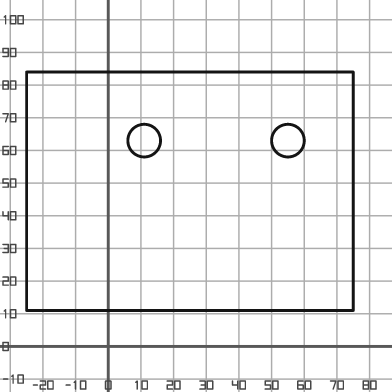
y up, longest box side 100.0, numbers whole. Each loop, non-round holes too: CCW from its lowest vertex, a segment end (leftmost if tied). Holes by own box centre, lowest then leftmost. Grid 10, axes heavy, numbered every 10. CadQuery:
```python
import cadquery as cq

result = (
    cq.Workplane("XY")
    .moveTo(-25.0, 11.0)
    .lineTo(75.0, 11.0)
    .lineTo(75.0, 84.0)
    .lineTo(-25.0, 84.0)
    .close()
    .moveTo(11.0, 63.0)
    .circle(5.0)
    .moveTo(55.0, 63.0)
    .circle(5.0)
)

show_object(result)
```